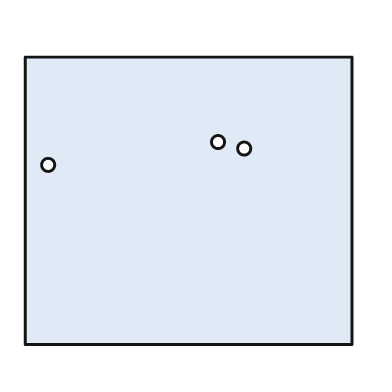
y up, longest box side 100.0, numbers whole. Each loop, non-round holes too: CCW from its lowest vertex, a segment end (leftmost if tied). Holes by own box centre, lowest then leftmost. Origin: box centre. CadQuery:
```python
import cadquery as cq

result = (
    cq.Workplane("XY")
    .moveTo(-50.0, -44.0)
    .lineTo(50.0, -44.0)
    .lineTo(50.0, 44.0)
    .lineTo(-50.0, 44.0)
    .close()
    .moveTo(-43.0, 11.0)
    .circle(2.0)
    .moveTo(17.0, 16.0)
    .circle(2.0)
    .moveTo(9.0, 18.0)
    .circle(2.0)
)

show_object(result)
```